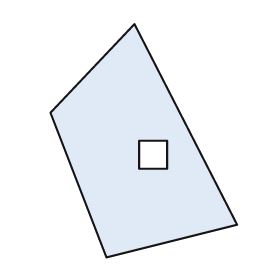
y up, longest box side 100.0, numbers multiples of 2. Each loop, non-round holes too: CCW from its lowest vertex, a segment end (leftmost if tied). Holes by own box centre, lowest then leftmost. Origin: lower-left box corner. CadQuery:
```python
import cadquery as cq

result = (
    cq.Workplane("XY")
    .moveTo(24.0, 0.0)
    .lineTo(80.0, 14.0)
    .lineTo(36.0, 100.0)
    .lineTo(0.0, 62.0)
    .close()
    .moveTo(38.0, 38.0)
    .lineTo(50.0, 38.0)
    .lineTo(50.0, 50.0)
    .lineTo(38.0, 50.0)
    .close()
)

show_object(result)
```